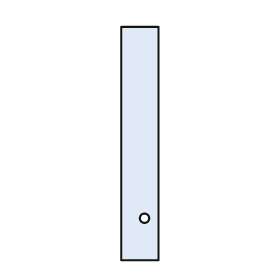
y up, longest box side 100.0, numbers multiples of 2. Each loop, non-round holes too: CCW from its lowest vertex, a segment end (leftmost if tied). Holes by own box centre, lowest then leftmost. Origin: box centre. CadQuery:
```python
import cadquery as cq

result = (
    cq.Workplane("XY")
    .moveTo(-8.0, -50.0)
    .lineTo(8.0, -50.0)
    .lineTo(8.0, 50.0)
    .lineTo(-8.0, 50.0)
    .close()
    .moveTo(2.0, -32.0)
    .circle(2.0)
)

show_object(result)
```